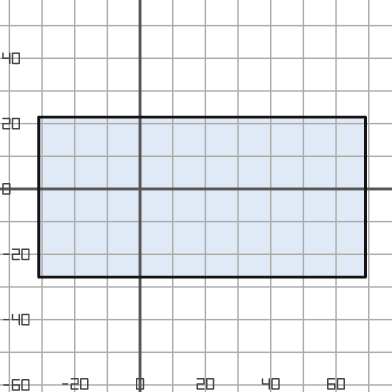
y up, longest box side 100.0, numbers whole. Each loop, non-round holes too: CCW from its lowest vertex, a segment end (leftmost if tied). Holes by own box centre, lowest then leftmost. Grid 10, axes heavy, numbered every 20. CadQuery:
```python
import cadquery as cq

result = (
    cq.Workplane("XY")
    .moveTo(-31.0, -27.0)
    .lineTo(69.0, -27.0)
    .lineTo(69.0, 22.0)
    .lineTo(-31.0, 22.0)
    .close()
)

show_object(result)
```